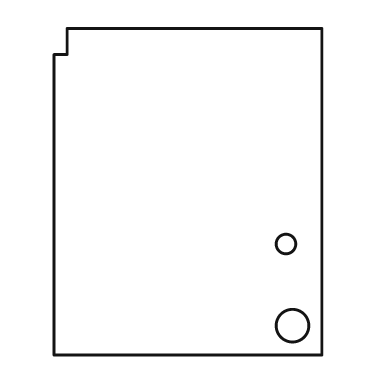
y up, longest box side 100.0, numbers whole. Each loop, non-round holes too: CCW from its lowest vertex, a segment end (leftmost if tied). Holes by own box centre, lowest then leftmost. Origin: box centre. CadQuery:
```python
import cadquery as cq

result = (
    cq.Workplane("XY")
    .moveTo(-41.0, -50.0)
    .lineTo(41.0, -50.0)
    .lineTo(41.0, 50.0)
    .lineTo(-37.0, 50.0)
    .lineTo(-37.0, 42.0)
    .lineTo(-41.0, 42.0)
    .close()
    .moveTo(32.0, -41.0)
    .circle(5.0)
    .moveTo(30.0, -16.0)
    .circle(3.0)
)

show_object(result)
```